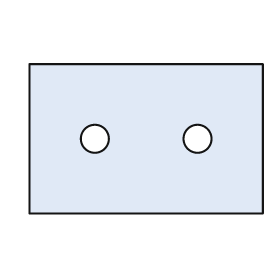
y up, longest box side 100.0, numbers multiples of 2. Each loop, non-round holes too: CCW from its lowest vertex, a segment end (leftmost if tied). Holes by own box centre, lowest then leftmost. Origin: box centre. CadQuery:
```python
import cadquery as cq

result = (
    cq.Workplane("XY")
    .moveTo(-50.0, -32.0)
    .lineTo(50.0, -32.0)
    .lineTo(50.0, 32.0)
    .lineTo(-50.0, 32.0)
    .close()
    .moveTo(-22.0, 0.0)
    .circle(6.0)
    .moveTo(22.0, 0.0)
    .circle(6.0)
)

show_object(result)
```